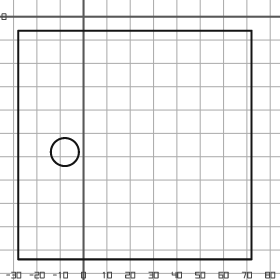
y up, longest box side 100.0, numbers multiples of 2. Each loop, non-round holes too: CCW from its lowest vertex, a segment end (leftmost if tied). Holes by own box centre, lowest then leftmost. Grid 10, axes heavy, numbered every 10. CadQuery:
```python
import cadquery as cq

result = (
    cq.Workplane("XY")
    .moveTo(-28.0, -104.0)
    .lineTo(72.0, -104.0)
    .lineTo(72.0, -6.0)
    .lineTo(-28.0, -6.0)
    .close()
    .moveTo(-8.0, -58.0)
    .circle(6.0)
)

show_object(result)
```